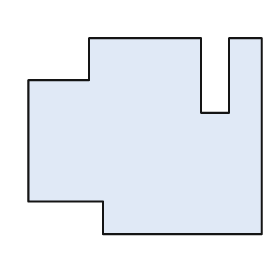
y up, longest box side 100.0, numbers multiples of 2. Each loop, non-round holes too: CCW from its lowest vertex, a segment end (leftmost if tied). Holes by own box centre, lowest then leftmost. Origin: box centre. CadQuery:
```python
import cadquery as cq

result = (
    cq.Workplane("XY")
    .moveTo(-18.0, -42.0)
    .lineTo(50.0, -42.0)
    .lineTo(50.0, 42.0)
    .lineTo(36.0, 42.0)
    .lineTo(36.0, 10.0)
    .lineTo(24.0, 10.0)
    .lineTo(24.0, 42.0)
    .lineTo(-24.0, 42.0)
    .lineTo(-24.0, 24.0)
    .lineTo(-50.0, 24.0)
    .lineTo(-50.0, -28.0)
    .lineTo(-18.0, -28.0)
    .close()
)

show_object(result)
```